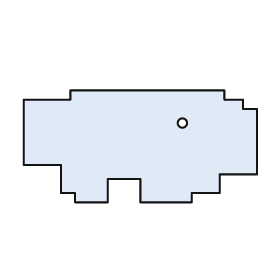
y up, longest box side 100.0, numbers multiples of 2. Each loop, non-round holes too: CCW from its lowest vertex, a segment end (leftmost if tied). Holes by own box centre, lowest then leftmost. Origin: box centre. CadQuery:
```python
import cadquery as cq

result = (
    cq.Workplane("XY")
    .moveTo(-28.0, -24.0)
    .lineTo(-14.0, -24.0)
    .lineTo(-14.0, -14.0)
    .lineTo(0.0, -14.0)
    .lineTo(0.0, -24.0)
    .lineTo(22.0, -24.0)
    .lineTo(22.0, -20.0)
    .lineTo(34.0, -20.0)
    .lineTo(34.0, -12.0)
    .lineTo(50.0, -12.0)
    .lineTo(50.0, 16.0)
    .lineTo(44.0, 16.0)
    .lineTo(44.0, 20.0)
    .lineTo(36.0, 20.0)
    .lineTo(36.0, 24.0)
    .lineTo(-30.0, 24.0)
    .lineTo(-30.0, 20.0)
    .lineTo(-50.0, 20.0)
    .lineTo(-50.0, -8.0)
    .lineTo(-34.0, -8.0)
    .lineTo(-34.0, -20.0)
    .lineTo(-28.0, -20.0)
    .close()
    .moveTo(18.0, 10.0)
    .circle(2.0)
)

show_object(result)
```